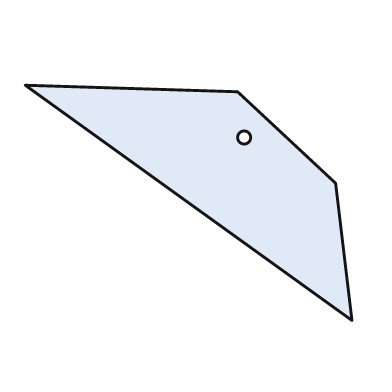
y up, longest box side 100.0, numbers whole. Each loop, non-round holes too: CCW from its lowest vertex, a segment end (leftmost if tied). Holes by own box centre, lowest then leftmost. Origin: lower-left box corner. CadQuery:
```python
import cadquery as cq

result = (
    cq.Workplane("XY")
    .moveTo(100.0, 0.0)
    .lineTo(95.0, 42.0)
    .lineTo(65.0, 70.0)
    .lineTo(0.0, 72.0)
    .close()
    .moveTo(67.0, 56.0)
    .circle(2.0)
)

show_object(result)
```